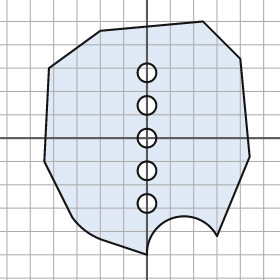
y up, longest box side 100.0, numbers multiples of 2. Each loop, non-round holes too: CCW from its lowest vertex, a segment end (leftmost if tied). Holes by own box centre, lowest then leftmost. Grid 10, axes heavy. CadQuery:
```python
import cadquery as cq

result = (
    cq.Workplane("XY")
    .moveTo(0.0, -50.0)
    .threePointArc((12.0, -34.0), (30.0, -42.0))
    .lineTo(44.0, -8.0)
    .lineTo(40.0, 34.0)
    .lineTo(24.0, 50.0)
    .lineTo(-20.0, 46.0)
    .lineTo(-42.0, 30.0)
    .lineTo(-44.0, -10.0)
    .lineTo(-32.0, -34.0)
    .threePointArc((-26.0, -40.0), (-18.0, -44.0))
    .close()
    .moveTo(0.0, -28.0)
    .circle(4.0)
    .moveTo(0.0, -14.0)
    .circle(4.0)
    .moveTo(0.0, 0.0)
    .circle(4.0)
    .moveTo(0.0, 14.0)
    .circle(4.0)
    .moveTo(0.0, 28.0)
    .circle(4.0)
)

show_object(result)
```